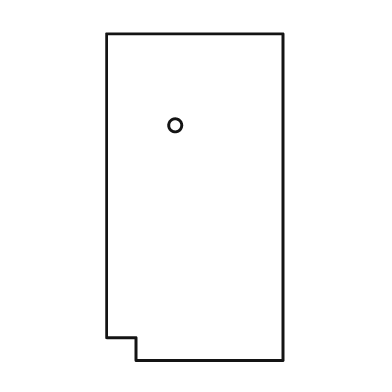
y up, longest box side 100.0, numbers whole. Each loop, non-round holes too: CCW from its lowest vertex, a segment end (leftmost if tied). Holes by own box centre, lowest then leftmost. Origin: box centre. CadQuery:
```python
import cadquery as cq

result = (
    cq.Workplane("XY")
    .moveTo(-18.0, -50.0)
    .lineTo(27.0, -50.0)
    .lineTo(27.0, 50.0)
    .lineTo(-27.0, 50.0)
    .lineTo(-27.0, -43.0)
    .lineTo(-18.0, -43.0)
    .close()
    .moveTo(-6.0, 22.0)
    .circle(2.0)
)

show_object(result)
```